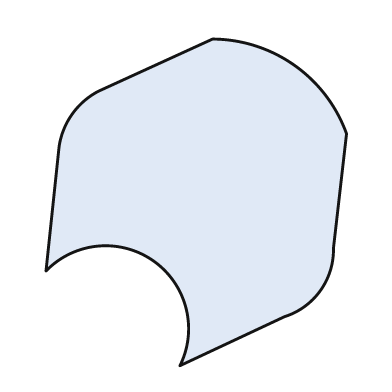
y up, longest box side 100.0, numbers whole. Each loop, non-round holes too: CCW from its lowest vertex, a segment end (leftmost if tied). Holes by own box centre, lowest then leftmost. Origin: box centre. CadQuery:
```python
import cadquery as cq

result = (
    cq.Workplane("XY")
    .moveTo(-5.0, -50.0)
    .lineTo(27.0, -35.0)
    .threePointArc((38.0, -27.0), (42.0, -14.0))
    .lineTo(46.0, 21.0)
    .threePointArc((30.0, 42.0), (5.0, 50.0))
    .lineTo(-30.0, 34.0)
    .threePointArc((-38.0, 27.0), (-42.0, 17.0))
    .lineTo(-46.0, -21.0)
    .threePointArc((-13.0, -18.0), (-5.0, -50.0))
    .close()
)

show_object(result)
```